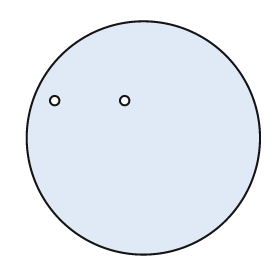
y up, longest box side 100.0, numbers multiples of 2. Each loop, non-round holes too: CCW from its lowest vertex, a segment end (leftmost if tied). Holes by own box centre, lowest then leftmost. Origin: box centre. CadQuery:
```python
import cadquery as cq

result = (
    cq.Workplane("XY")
    .moveTo(0.0, 0.0)
    .circle(50.0)
    .moveTo(-38.0, 16.0)
    .circle(2.0)
    .moveTo(-8.0, 16.0)
    .circle(2.0)
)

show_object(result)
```